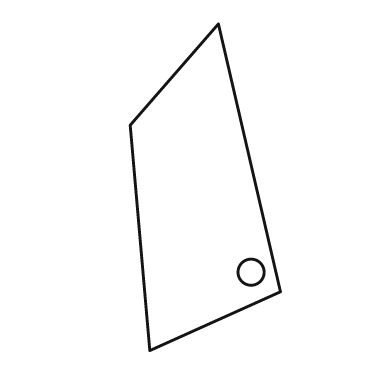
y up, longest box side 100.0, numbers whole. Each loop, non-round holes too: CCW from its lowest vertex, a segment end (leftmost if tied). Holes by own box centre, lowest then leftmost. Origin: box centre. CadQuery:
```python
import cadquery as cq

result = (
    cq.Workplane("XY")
    .moveTo(-17.0, -50.0)
    .lineTo(23.0, -32.0)
    .lineTo(4.0, 50.0)
    .lineTo(-23.0, 19.0)
    .close()
    .moveTo(14.0, -26.0)
    .circle(4.0)
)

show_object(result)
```